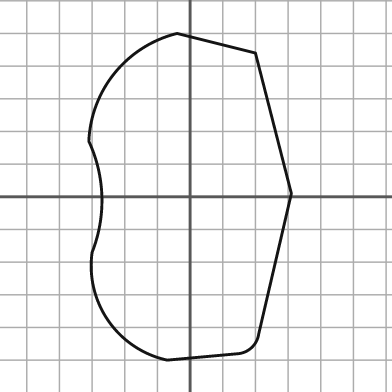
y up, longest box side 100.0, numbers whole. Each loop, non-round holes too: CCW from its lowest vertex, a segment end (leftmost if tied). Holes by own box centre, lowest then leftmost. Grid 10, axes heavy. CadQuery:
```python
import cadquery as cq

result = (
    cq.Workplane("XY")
    .moveTo(-7.0, -50.0)
    .lineTo(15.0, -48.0)
    .threePointArc((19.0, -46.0), (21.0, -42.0))
    .lineTo(31.0, 1.0)
    .lineTo(20.0, 44.0)
    .lineTo(-4.0, 50.0)
    .threePointArc((-23.0, 38.0), (-31.0, 17.0))
    .threePointArc((-27.0, 0.0), (-30.0, -17.0))
    .threePointArc((-25.0, -38.0), (-7.0, -50.0))
    .close()
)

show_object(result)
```